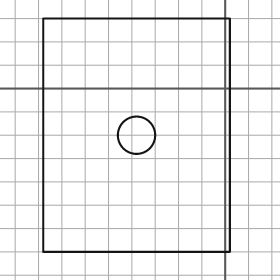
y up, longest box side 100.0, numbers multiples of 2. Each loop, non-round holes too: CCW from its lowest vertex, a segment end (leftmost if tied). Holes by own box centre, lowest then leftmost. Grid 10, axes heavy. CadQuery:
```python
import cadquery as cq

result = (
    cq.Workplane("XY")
    .moveTo(-78.0, -70.0)
    .lineTo(2.0, -70.0)
    .lineTo(2.0, 30.0)
    .lineTo(-78.0, 30.0)
    .close()
    .moveTo(-38.0, -20.0)
    .circle(8.0)
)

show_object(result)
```